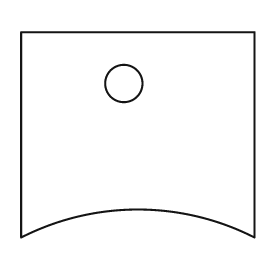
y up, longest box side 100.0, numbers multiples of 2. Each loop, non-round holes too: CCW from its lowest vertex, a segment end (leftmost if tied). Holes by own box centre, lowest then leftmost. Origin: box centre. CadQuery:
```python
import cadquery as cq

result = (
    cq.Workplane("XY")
    .moveTo(-50.0, -44.0)
    .threePointArc((0.0, -32.0), (50.0, -44.0))
    .lineTo(50.0, 44.0)
    .lineTo(-50.0, 44.0)
    .close()
    .moveTo(-6.0, 22.0)
    .circle(8.0)
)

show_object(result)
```